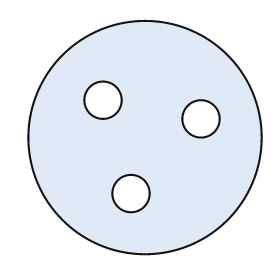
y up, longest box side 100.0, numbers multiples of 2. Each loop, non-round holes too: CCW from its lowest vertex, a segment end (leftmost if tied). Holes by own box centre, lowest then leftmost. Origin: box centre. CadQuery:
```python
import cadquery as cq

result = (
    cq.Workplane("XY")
    .moveTo(0.0, 0.0)
    .circle(50.0)
    .moveTo(-6.0, -24.0)
    .circle(8.0)
    .moveTo(24.0, 8.0)
    .circle(8.0)
    .moveTo(-18.0, 16.0)
    .circle(8.0)
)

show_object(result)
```